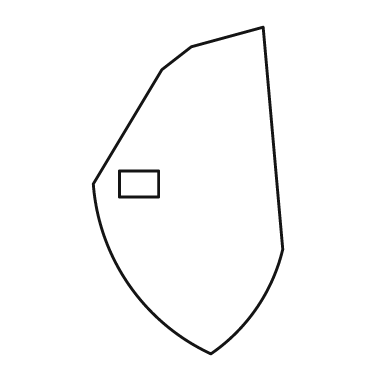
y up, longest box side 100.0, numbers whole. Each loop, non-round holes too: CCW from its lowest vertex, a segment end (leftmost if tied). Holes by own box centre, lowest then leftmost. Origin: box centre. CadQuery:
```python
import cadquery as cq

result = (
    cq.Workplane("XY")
    .moveTo(7.0, -50.0)
    .threePointArc((21.0, -36.0), (29.0, -18.0))
    .lineTo(23.0, 50.0)
    .lineTo(1.0, 44.0)
    .lineTo(-8.0, 37.0)
    .lineTo(-29.0, 2.0)
    .threePointArc((-18.0, -29.0), (7.0, -50.0))
    .close()
    .moveTo(-21.0, -2.0)
    .lineTo(-9.0, -2.0)
    .lineTo(-9.0, 6.0)
    .lineTo(-21.0, 6.0)
    .close()
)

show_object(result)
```